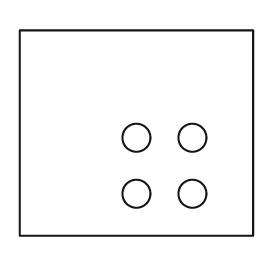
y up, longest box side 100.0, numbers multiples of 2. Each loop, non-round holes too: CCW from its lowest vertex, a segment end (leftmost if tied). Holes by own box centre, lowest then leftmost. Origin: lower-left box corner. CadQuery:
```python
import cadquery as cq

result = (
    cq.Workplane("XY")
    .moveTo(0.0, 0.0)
    .lineTo(100.0, 0.0)
    .lineTo(100.0, 88.0)
    .lineTo(0.0, 88.0)
    .close()
    .moveTo(50.0, 18.0)
    .circle(6.0)
    .moveTo(74.0, 18.0)
    .circle(6.0)
    .moveTo(50.0, 42.0)
    .circle(6.0)
    .moveTo(74.0, 42.0)
    .circle(6.0)
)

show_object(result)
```